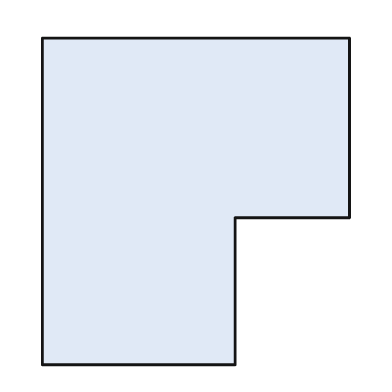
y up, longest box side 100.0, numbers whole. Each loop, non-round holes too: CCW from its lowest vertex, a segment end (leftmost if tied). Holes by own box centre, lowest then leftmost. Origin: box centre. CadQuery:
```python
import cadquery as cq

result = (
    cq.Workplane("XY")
    .moveTo(-47.0, -50.0)
    .lineTo(12.0, -50.0)
    .lineTo(12.0, -5.0)
    .lineTo(47.0, -5.0)
    .lineTo(47.0, 50.0)
    .lineTo(-47.0, 50.0)
    .close()
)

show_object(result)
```